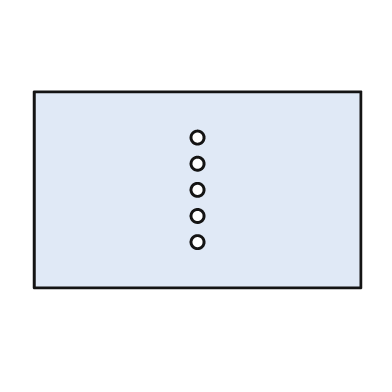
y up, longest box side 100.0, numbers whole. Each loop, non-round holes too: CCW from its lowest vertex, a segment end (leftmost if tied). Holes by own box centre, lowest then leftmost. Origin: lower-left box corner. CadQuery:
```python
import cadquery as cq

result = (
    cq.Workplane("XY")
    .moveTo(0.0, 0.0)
    .lineTo(100.0, 0.0)
    .lineTo(100.0, 60.0)
    .lineTo(0.0, 60.0)
    .close()
    .moveTo(50.0, 14.0)
    .circle(2.0)
    .moveTo(50.0, 22.0)
    .circle(2.0)
    .moveTo(50.0, 30.0)
    .circle(2.0)
    .moveTo(50.0, 38.0)
    .circle(2.0)
    .moveTo(50.0, 46.0)
    .circle(2.0)
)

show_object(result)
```